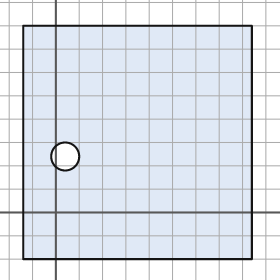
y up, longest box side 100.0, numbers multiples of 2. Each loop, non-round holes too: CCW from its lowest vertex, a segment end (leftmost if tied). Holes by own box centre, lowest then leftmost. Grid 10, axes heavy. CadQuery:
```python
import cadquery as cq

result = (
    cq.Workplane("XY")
    .moveTo(-14.0, -20.0)
    .lineTo(84.0, -20.0)
    .lineTo(84.0, 80.0)
    .lineTo(-14.0, 80.0)
    .close()
    .moveTo(4.0, 24.0)
    .circle(6.0)
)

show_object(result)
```